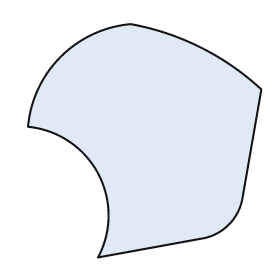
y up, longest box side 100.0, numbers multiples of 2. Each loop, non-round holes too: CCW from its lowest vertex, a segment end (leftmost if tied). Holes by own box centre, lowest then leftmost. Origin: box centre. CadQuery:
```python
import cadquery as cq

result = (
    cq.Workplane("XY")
    .moveTo(-20.0, -50.0)
    .lineTo(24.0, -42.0)
    .threePointArc((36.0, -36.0), (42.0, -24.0))
    .lineTo(50.0, 22.0)
    .threePointArc((24.0, 40.0), (-6.0, 50.0))
    .threePointArc((-36.0, 36.0), (-50.0, 6.0))
    .threePointArc((-20.0, -14.0), (-20.0, -50.0))
    .close()
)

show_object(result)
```